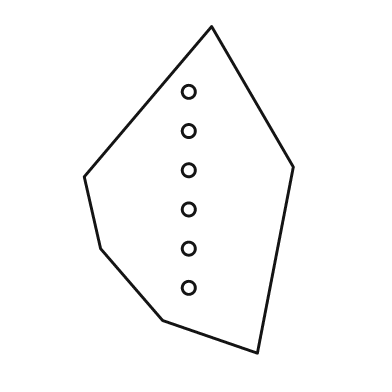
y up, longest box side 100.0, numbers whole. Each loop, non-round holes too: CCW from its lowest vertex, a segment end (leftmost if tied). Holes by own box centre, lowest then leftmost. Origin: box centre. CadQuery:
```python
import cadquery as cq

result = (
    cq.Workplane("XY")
    .moveTo(21.0, -50.0)
    .lineTo(32.0, 7.0)
    .lineTo(7.0, 50.0)
    .lineTo(-32.0, 4.0)
    .lineTo(-27.0, -18.0)
    .lineTo(-8.0, -40.0)
    .close()
    .moveTo(0.0, -30.0)
    .circle(2.0)
    .moveTo(0.0, -18.0)
    .circle(2.0)
    .moveTo(0.0, -6.0)
    .circle(2.0)
    .moveTo(0.0, 6.0)
    .circle(2.0)
    .moveTo(0.0, 18.0)
    .circle(2.0)
    .moveTo(0.0, 30.0)
    .circle(2.0)
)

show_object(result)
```